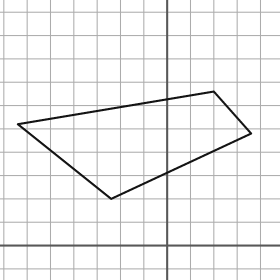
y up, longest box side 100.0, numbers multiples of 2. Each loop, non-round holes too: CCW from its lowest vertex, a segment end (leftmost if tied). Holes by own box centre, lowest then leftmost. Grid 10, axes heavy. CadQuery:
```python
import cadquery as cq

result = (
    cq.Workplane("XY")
    .moveTo(-24.0, 20.0)
    .lineTo(36.0, 48.0)
    .lineTo(20.0, 66.0)
    .lineTo(-64.0, 52.0)
    .close()
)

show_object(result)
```